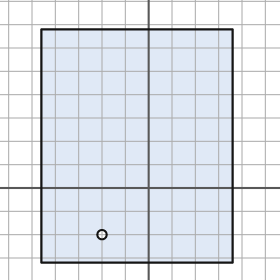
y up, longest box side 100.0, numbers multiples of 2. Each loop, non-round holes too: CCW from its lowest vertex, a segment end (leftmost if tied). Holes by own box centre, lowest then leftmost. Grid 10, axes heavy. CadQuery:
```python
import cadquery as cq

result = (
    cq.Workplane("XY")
    .moveTo(-46.0, -32.0)
    .lineTo(36.0, -32.0)
    .lineTo(36.0, 68.0)
    .lineTo(-46.0, 68.0)
    .close()
    .moveTo(-20.0, -20.0)
    .circle(2.0)
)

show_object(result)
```